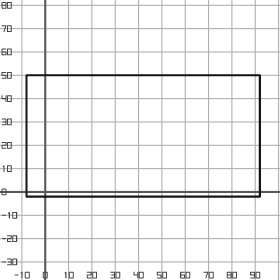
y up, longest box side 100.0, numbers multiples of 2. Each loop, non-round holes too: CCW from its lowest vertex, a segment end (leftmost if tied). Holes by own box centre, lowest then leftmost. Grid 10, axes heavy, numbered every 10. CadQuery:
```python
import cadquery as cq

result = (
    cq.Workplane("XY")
    .moveTo(-8.0, -2.0)
    .lineTo(92.0, -2.0)
    .lineTo(92.0, 50.0)
    .lineTo(-8.0, 50.0)
    .close()
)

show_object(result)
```